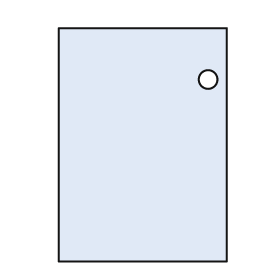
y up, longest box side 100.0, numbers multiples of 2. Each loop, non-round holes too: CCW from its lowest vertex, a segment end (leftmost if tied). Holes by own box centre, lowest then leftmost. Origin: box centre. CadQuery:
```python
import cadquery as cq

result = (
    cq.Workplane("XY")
    .moveTo(-36.0, -50.0)
    .lineTo(36.0, -50.0)
    .lineTo(36.0, 50.0)
    .lineTo(-36.0, 50.0)
    .close()
    .moveTo(28.0, 28.0)
    .circle(4.0)
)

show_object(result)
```